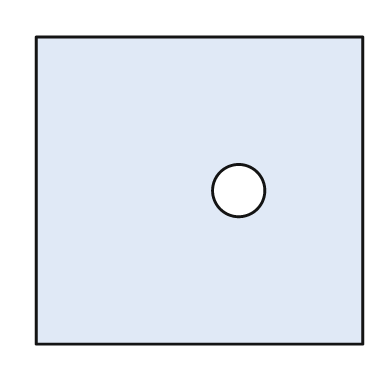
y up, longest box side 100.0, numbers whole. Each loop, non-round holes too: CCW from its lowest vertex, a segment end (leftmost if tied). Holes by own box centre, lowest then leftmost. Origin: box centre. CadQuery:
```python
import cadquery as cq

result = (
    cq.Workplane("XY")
    .moveTo(-50.0, -47.0)
    .lineTo(50.0, -47.0)
    .lineTo(50.0, 47.0)
    .lineTo(-50.0, 47.0)
    .close()
    .moveTo(12.0, 0.0)
    .circle(8.0)
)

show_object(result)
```